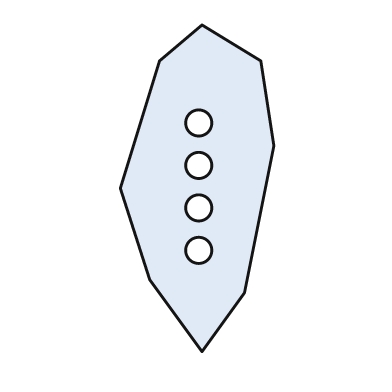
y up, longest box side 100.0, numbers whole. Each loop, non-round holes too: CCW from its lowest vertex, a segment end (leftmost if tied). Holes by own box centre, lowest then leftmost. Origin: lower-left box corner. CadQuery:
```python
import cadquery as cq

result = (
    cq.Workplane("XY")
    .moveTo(25.0, 0.0)
    .lineTo(38.0, 18.0)
    .lineTo(47.0, 63.0)
    .lineTo(43.0, 89.0)
    .lineTo(25.0, 100.0)
    .lineTo(12.0, 89.0)
    .lineTo(0.0, 50.0)
    .lineTo(9.0, 22.0)
    .close()
    .moveTo(24.0, 31.0)
    .circle(4.0)
    .moveTo(24.0, 44.0)
    .circle(4.0)
    .moveTo(24.0, 57.0)
    .circle(4.0)
    .moveTo(24.0, 70.0)
    .circle(4.0)
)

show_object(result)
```